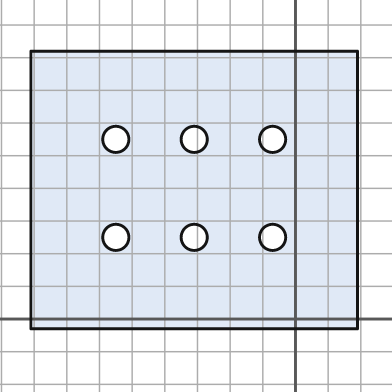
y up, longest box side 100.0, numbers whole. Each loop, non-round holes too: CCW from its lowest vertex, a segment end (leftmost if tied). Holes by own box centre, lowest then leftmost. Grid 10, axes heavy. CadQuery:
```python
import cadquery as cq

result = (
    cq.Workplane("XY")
    .moveTo(-81.0, -3.0)
    .lineTo(19.0, -3.0)
    .lineTo(19.0, 82.0)
    .lineTo(-81.0, 82.0)
    .close()
    .moveTo(-55.0, 25.0)
    .circle(4.0)
    .moveTo(-31.0, 25.0)
    .circle(4.0)
    .moveTo(-7.0, 25.0)
    .circle(4.0)
    .moveTo(-55.0, 55.0)
    .circle(4.0)
    .moveTo(-31.0, 55.0)
    .circle(4.0)
    .moveTo(-7.0, 55.0)
    .circle(4.0)
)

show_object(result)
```